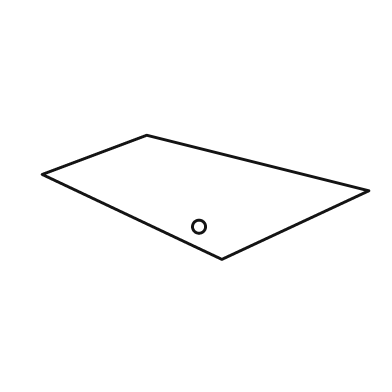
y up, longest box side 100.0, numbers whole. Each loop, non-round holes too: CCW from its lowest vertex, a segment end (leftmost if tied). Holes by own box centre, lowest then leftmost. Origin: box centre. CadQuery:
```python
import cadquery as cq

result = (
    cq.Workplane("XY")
    .moveTo(5.0, -19.0)
    .lineTo(50.0, 2.0)
    .lineTo(-18.0, 19.0)
    .lineTo(-50.0, 7.0)
    .close()
    .moveTo(-2.0, -9.0)
    .circle(2.0)
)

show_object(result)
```